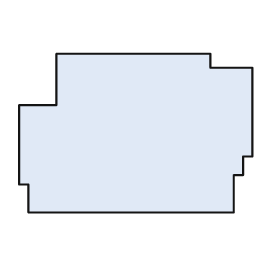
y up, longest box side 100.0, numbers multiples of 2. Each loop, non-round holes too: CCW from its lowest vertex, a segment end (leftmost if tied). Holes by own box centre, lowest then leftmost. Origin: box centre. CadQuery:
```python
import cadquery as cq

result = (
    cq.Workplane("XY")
    .moveTo(-46.0, -34.0)
    .lineTo(42.0, -34.0)
    .lineTo(42.0, -18.0)
    .lineTo(46.0, -18.0)
    .lineTo(46.0, -10.0)
    .lineTo(50.0, -10.0)
    .lineTo(50.0, 28.0)
    .lineTo(32.0, 28.0)
    .lineTo(32.0, 34.0)
    .lineTo(-34.0, 34.0)
    .lineTo(-34.0, 12.0)
    .lineTo(-50.0, 12.0)
    .lineTo(-50.0, -22.0)
    .lineTo(-46.0, -22.0)
    .close()
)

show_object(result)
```